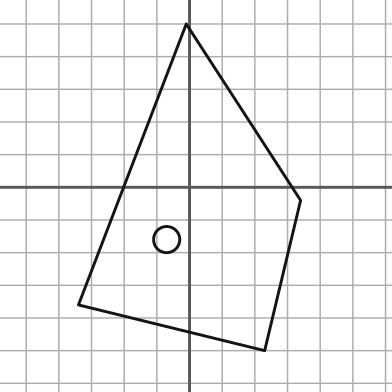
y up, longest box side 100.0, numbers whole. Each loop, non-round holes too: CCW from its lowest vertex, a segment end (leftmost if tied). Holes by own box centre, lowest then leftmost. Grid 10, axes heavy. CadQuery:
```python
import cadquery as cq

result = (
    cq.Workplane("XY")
    .moveTo(23.0, -50.0)
    .lineTo(34.0, -4.0)
    .lineTo(-1.0, 50.0)
    .lineTo(-34.0, -36.0)
    .close()
    .moveTo(-7.0, -16.0)
    .circle(4.0)
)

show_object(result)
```